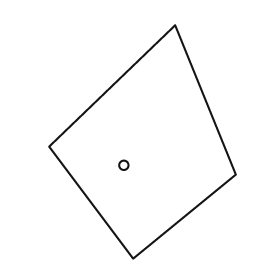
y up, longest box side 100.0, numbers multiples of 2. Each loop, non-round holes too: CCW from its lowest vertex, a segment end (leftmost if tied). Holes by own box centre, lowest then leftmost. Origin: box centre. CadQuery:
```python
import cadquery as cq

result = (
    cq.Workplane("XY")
    .moveTo(-4.0, -50.0)
    .lineTo(40.0, -14.0)
    .lineTo(14.0, 50.0)
    .lineTo(-40.0, -2.0)
    .close()
    .moveTo(-8.0, -10.0)
    .circle(2.0)
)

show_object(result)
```